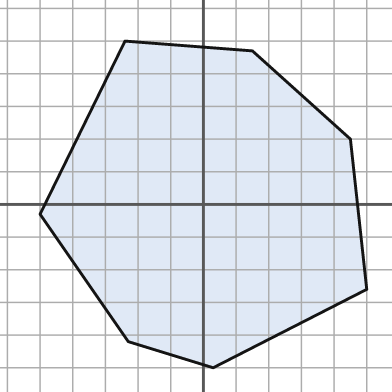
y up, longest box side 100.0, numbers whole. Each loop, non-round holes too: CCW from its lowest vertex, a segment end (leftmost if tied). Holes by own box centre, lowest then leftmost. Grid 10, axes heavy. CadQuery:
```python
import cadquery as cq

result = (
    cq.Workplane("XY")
    .moveTo(3.0, -50.0)
    .lineTo(50.0, -26.0)
    .lineTo(45.0, 20.0)
    .lineTo(15.0, 47.0)
    .lineTo(-24.0, 50.0)
    .lineTo(-50.0, -3.0)
    .lineTo(-23.0, -42.0)
    .close()
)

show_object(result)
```